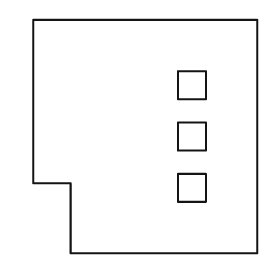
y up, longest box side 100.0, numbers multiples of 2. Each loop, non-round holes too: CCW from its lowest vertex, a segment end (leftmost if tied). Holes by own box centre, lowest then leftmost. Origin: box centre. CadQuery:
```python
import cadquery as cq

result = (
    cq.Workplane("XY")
    .moveTo(-32.0, -50.0)
    .lineTo(48.0, -50.0)
    .lineTo(48.0, 50.0)
    .lineTo(-48.0, 50.0)
    .lineTo(-48.0, -20.0)
    .lineTo(-32.0, -20.0)
    .close()
    .moveTo(14.0, -28.0)
    .lineTo(26.0, -28.0)
    .lineTo(26.0, -16.0)
    .lineTo(14.0, -16.0)
    .close()
    .moveTo(14.0, -6.0)
    .lineTo(26.0, -6.0)
    .lineTo(26.0, 6.0)
    .lineTo(14.0, 6.0)
    .close()
    .moveTo(14.0, 16.0)
    .lineTo(26.0, 16.0)
    .lineTo(26.0, 28.0)
    .lineTo(14.0, 28.0)
    .close()
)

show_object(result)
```